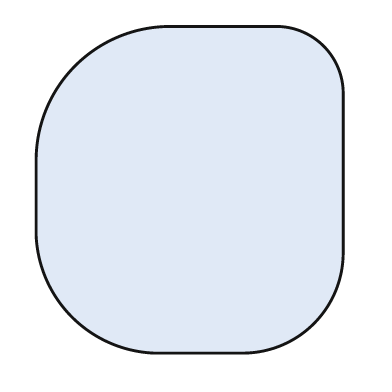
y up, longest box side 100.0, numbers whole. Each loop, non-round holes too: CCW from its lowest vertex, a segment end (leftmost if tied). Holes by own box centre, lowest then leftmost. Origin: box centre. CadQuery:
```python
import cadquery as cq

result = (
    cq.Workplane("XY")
    .moveTo(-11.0, -50.0)
    .lineTo(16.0, -50.0)
    .threePointArc((38.0, -41.0), (47.0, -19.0))
    .lineTo(47.0, 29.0)
    .threePointArc((41.0, 44.0), (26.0, 50.0))
    .lineTo(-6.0, 50.0)
    .threePointArc((-35.0, 38.0), (-47.0, 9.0))
    .lineTo(-47.0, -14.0)
    .threePointArc((-36.0, -39.0), (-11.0, -50.0))
    .close()
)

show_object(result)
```